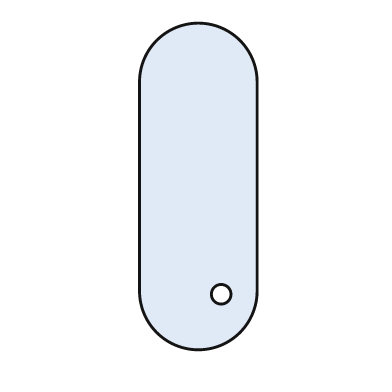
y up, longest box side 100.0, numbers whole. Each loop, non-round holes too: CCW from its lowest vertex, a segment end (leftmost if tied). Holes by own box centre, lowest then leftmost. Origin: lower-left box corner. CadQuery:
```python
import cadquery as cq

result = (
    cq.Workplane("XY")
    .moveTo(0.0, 18.0)
    .threePointArc((18.0, 0.0), (36.0, 18.0))
    .lineTo(36.0, 82.0)
    .threePointArc((18.0, 100.0), (0.0, 82.0))
    .close()
    .moveTo(25.0, 17.0)
    .circle(3.0)
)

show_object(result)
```